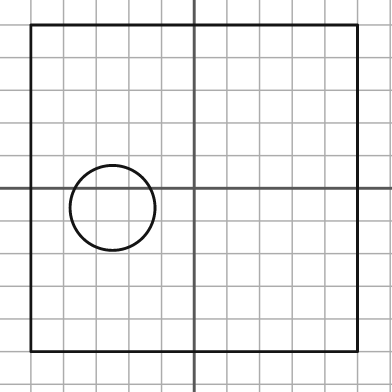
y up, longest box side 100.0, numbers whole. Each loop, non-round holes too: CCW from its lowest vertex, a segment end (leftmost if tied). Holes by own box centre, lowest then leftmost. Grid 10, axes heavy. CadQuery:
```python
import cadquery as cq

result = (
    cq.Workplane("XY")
    .moveTo(-50.0, -50.0)
    .lineTo(50.0, -50.0)
    .lineTo(50.0, 50.0)
    .lineTo(-50.0, 50.0)
    .close()
    .moveTo(-25.0, -6.0)
    .circle(13.0)
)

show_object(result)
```